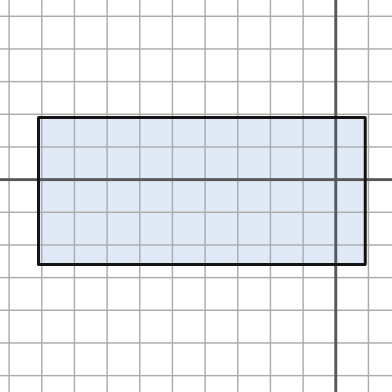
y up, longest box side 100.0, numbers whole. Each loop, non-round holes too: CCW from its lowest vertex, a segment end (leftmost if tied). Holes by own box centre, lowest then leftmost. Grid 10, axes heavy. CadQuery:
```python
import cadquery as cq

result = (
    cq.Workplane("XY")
    .moveTo(-91.0, -26.0)
    .lineTo(9.0, -26.0)
    .lineTo(9.0, 19.0)
    .lineTo(-91.0, 19.0)
    .close()
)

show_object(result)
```